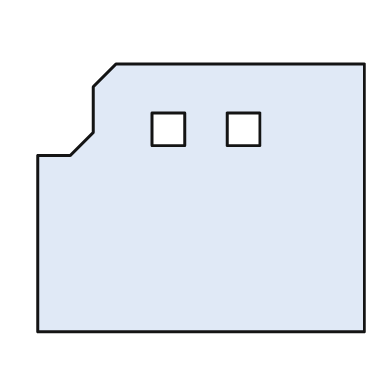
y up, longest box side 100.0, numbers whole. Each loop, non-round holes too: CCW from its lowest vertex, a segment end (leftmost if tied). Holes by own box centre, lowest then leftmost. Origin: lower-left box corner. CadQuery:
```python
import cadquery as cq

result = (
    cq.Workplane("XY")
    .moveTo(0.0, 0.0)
    .lineTo(100.0, 0.0)
    .lineTo(100.0, 82.0)
    .lineTo(24.0, 82.0)
    .lineTo(17.0, 75.0)
    .lineTo(17.0, 61.0)
    .lineTo(10.0, 54.0)
    .lineTo(0.0, 54.0)
    .close()
    .moveTo(35.0, 57.0)
    .lineTo(45.0, 57.0)
    .lineTo(45.0, 67.0)
    .lineTo(35.0, 67.0)
    .close()
    .moveTo(58.0, 57.0)
    .lineTo(68.0, 57.0)
    .lineTo(68.0, 67.0)
    .lineTo(58.0, 67.0)
    .close()
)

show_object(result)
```